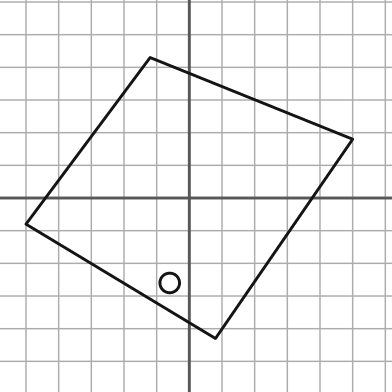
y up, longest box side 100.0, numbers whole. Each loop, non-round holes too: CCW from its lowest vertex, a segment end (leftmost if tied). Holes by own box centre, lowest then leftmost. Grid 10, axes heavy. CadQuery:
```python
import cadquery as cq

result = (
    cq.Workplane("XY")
    .moveTo(8.0, -43.0)
    .lineTo(50.0, 18.0)
    .lineTo(-12.0, 43.0)
    .lineTo(-50.0, -8.0)
    .close()
    .moveTo(-6.0, -26.0)
    .circle(3.0)
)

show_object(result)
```